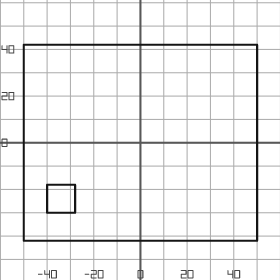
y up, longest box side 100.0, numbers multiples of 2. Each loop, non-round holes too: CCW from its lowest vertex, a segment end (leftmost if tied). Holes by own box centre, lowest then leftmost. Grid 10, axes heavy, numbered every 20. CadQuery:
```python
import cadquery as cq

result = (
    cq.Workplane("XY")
    .moveTo(-50.0, -42.0)
    .lineTo(50.0, -42.0)
    .lineTo(50.0, 42.0)
    .lineTo(-50.0, 42.0)
    .close()
    .moveTo(-40.0, -30.0)
    .lineTo(-28.0, -30.0)
    .lineTo(-28.0, -18.0)
    .lineTo(-40.0, -18.0)
    .close()
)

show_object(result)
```